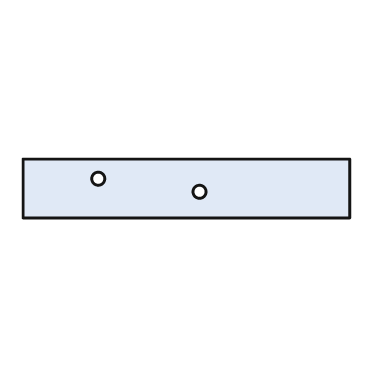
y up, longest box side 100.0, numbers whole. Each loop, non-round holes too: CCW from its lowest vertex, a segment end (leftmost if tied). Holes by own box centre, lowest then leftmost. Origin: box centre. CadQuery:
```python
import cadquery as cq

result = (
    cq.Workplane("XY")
    .moveTo(-50.0, -9.0)
    .lineTo(50.0, -9.0)
    .lineTo(50.0, 9.0)
    .lineTo(-50.0, 9.0)
    .close()
    .moveTo(4.0, -1.0)
    .circle(2.0)
    .moveTo(-27.0, 3.0)
    .circle(2.0)
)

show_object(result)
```